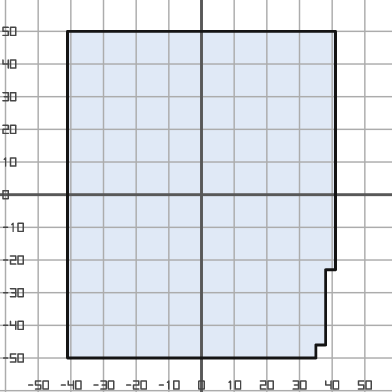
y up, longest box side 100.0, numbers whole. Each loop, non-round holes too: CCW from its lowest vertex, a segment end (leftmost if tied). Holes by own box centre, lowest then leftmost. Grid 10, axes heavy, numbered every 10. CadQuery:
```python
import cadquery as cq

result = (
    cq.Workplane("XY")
    .moveTo(-41.0, -50.0)
    .lineTo(35.0, -50.0)
    .lineTo(35.0, -46.0)
    .lineTo(38.0, -46.0)
    .lineTo(38.0, -23.0)
    .lineTo(41.0, -23.0)
    .lineTo(41.0, 50.0)
    .lineTo(-41.0, 50.0)
    .close()
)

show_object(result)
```